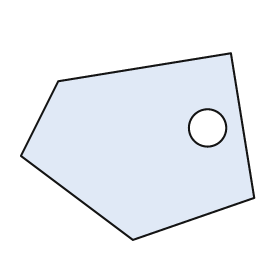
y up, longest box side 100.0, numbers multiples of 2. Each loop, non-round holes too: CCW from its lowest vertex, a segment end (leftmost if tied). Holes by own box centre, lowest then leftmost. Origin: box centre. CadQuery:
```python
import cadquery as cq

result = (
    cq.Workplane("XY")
    .moveTo(-2.0, -40.0)
    .lineTo(50.0, -22.0)
    .lineTo(40.0, 40.0)
    .lineTo(-34.0, 28.0)
    .lineTo(-50.0, -4.0)
    .close()
    .moveTo(30.0, 8.0)
    .circle(8.0)
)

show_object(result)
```